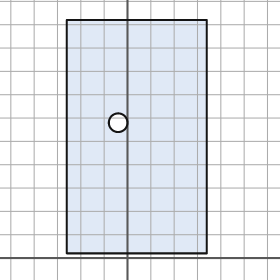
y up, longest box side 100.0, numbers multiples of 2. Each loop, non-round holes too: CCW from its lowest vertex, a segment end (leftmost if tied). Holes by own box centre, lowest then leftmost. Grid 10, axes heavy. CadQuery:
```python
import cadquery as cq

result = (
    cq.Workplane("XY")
    .moveTo(-26.0, 2.0)
    .lineTo(34.0, 2.0)
    .lineTo(34.0, 102.0)
    .lineTo(-26.0, 102.0)
    .close()
    .moveTo(-4.0, 58.0)
    .circle(4.0)
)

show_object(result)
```